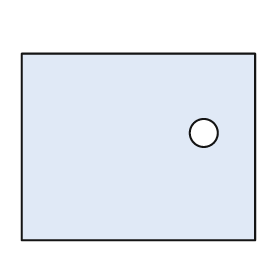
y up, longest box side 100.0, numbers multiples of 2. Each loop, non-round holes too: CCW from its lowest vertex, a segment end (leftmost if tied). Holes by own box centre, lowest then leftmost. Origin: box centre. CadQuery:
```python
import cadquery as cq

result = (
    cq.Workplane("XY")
    .moveTo(-50.0, -40.0)
    .lineTo(50.0, -40.0)
    .lineTo(50.0, 40.0)
    .lineTo(-50.0, 40.0)
    .close()
    .moveTo(28.0, 6.0)
    .circle(6.0)
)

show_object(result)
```